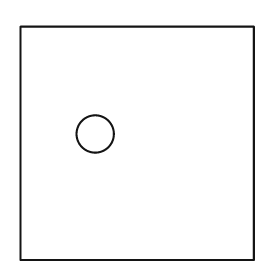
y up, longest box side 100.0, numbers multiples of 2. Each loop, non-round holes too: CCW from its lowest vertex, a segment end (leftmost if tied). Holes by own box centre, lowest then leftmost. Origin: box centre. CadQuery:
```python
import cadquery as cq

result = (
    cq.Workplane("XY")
    .moveTo(-50.0, -50.0)
    .lineTo(50.0, -50.0)
    .lineTo(50.0, 50.0)
    .lineTo(-50.0, 50.0)
    .close()
    .moveTo(-18.0, 4.0)
    .circle(8.0)
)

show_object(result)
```